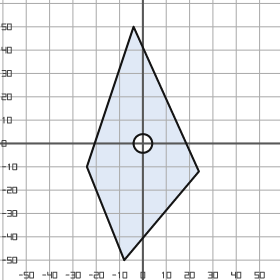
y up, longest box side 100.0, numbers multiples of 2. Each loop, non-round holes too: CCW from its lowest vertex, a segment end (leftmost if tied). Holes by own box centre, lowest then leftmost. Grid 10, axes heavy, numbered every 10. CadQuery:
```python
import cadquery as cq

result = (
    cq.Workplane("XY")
    .moveTo(-8.0, -50.0)
    .lineTo(24.0, -12.0)
    .lineTo(-4.0, 50.0)
    .lineTo(-24.0, -10.0)
    .close()
    .moveTo(0.0, 0.0)
    .circle(4.0)
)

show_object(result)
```